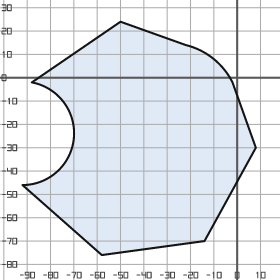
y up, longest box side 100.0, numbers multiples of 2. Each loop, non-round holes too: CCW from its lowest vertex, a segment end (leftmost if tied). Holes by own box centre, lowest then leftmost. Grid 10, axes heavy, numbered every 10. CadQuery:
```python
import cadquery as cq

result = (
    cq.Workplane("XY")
    .moveTo(-58.0, -76.0)
    .lineTo(-14.0, -70.0)
    .lineTo(8.0, -30.0)
    .lineTo(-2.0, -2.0)
    .threePointArc((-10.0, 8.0), (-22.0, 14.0))
    .lineTo(-50.0, 24.0)
    .lineTo(-88.0, -2.0)
    .threePointArc((-70.0, -26.0), (-92.0, -46.0))
    .close()
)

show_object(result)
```